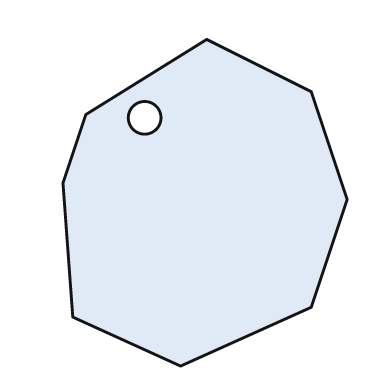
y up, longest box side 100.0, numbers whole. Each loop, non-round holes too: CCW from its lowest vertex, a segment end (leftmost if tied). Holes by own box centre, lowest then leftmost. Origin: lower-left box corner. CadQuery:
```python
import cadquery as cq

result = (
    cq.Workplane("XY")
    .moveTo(36.0, 0.0)
    .lineTo(76.0, 18.0)
    .lineTo(87.0, 51.0)
    .lineTo(76.0, 84.0)
    .lineTo(44.0, 100.0)
    .lineTo(7.0, 77.0)
    .lineTo(0.0, 56.0)
    .lineTo(3.0, 15.0)
    .close()
    .moveTo(25.0, 76.0)
    .circle(5.0)
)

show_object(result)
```